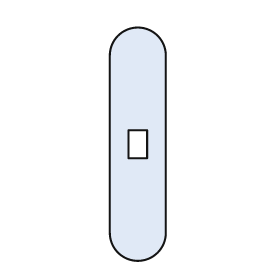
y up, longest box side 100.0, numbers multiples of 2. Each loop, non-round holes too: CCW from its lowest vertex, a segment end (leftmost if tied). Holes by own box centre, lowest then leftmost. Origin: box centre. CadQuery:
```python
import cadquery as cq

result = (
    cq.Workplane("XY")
    .moveTo(-12.0, -38.0)
    .threePointArc((0.0, -50.0), (12.0, -38.0))
    .lineTo(12.0, 38.0)
    .threePointArc((0.0, 50.0), (-12.0, 38.0))
    .close()
    .moveTo(-4.0, -6.0)
    .lineTo(4.0, -6.0)
    .lineTo(4.0, 6.0)
    .lineTo(-4.0, 6.0)
    .close()
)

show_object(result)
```